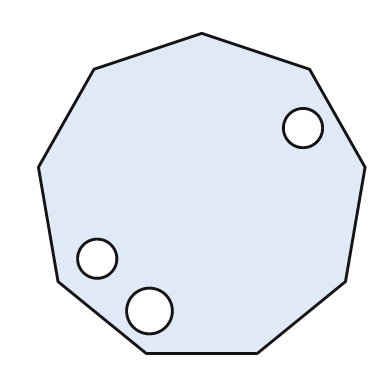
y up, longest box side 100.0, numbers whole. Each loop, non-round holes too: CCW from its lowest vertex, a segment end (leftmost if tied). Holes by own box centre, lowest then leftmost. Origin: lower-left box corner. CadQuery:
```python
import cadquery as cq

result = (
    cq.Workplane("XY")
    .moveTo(33.0, 0.0)
    .lineTo(67.0, 0.0)
    .lineTo(94.0, 22.0)
    .lineTo(100.0, 57.0)
    .lineTo(83.0, 87.0)
    .lineTo(50.0, 98.0)
    .lineTo(17.0, 87.0)
    .lineTo(0.0, 57.0)
    .lineTo(6.0, 22.0)
    .close()
    .moveTo(34.0, 13.0)
    .circle(7.0)
    .moveTo(18.0, 29.0)
    .circle(6.0)
    .moveTo(81.0, 69.0)
    .circle(6.0)
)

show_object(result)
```